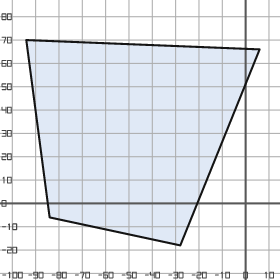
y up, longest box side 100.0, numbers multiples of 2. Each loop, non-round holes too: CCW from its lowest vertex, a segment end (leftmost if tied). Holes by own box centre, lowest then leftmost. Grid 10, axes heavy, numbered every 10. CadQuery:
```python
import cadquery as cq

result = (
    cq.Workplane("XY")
    .moveTo(-28.0, -18.0)
    .lineTo(6.0, 66.0)
    .lineTo(-94.0, 70.0)
    .lineTo(-84.0, -6.0)
    .close()
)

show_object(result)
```